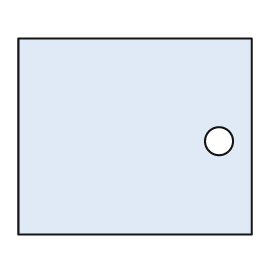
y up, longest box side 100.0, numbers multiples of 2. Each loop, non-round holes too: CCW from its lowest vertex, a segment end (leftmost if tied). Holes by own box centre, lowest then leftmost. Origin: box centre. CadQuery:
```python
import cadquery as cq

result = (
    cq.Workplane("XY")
    .moveTo(-50.0, -42.0)
    .lineTo(50.0, -42.0)
    .lineTo(50.0, 42.0)
    .lineTo(-50.0, 42.0)
    .close()
    .moveTo(36.0, -2.0)
    .circle(6.0)
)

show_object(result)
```